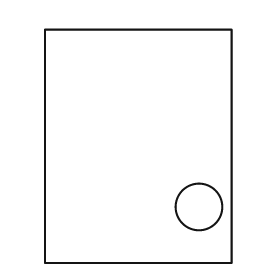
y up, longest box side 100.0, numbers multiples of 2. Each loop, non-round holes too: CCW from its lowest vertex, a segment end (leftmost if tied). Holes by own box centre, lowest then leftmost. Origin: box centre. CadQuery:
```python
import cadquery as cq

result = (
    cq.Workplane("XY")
    .moveTo(-40.0, -50.0)
    .lineTo(40.0, -50.0)
    .lineTo(40.0, 50.0)
    .lineTo(-40.0, 50.0)
    .close()
    .moveTo(26.0, -26.0)
    .circle(10.0)
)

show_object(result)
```